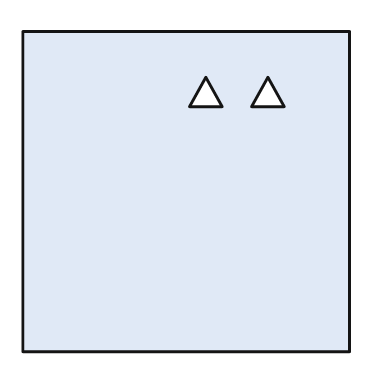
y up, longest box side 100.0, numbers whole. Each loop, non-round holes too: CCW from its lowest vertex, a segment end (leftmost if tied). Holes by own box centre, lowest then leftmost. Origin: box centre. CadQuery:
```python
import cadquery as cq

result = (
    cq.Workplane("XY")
    .moveTo(-50.0, -49.0)
    .lineTo(50.0, -49.0)
    .lineTo(50.0, 49.0)
    .lineTo(-50.0, 49.0)
    .close()
    .moveTo(1.0, 26.0)
    .lineTo(11.0, 26.0)
    .lineTo(6.0, 35.0)
    .close()
    .moveTo(20.0, 26.0)
    .lineTo(30.0, 26.0)
    .lineTo(25.0, 35.0)
    .close()
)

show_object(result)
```